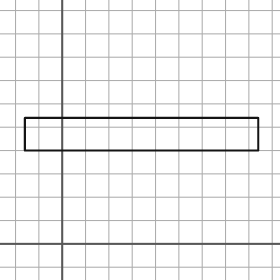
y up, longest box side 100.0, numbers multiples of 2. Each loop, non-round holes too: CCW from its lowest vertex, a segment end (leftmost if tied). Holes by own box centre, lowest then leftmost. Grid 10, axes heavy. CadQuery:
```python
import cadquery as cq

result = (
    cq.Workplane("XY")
    .moveTo(-16.0, 40.0)
    .lineTo(84.0, 40.0)
    .lineTo(84.0, 54.0)
    .lineTo(-16.0, 54.0)
    .close()
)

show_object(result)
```